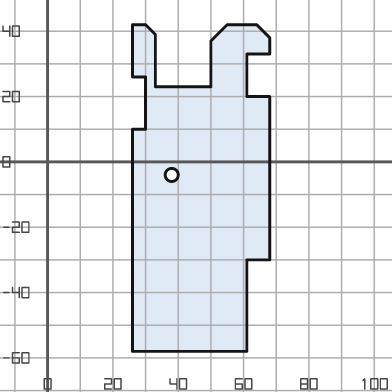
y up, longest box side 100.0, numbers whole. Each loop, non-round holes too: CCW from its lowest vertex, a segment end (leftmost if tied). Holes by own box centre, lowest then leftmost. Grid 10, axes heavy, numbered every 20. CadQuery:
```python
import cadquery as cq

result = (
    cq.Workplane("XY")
    .moveTo(26.0, -58.0)
    .lineTo(61.0, -58.0)
    .lineTo(61.0, -30.0)
    .lineTo(68.0, -30.0)
    .lineTo(68.0, 20.0)
    .lineTo(61.0, 20.0)
    .lineTo(61.0, 33.0)
    .lineTo(68.0, 33.0)
    .lineTo(68.0, 38.0)
    .lineTo(64.0, 42.0)
    .lineTo(55.0, 42.0)
    .lineTo(50.0, 37.0)
    .lineTo(50.0, 23.0)
    .lineTo(33.0, 23.0)
    .lineTo(33.0, 39.0)
    .lineTo(30.0, 42.0)
    .lineTo(26.0, 42.0)
    .lineTo(26.0, 26.0)
    .lineTo(30.0, 26.0)
    .lineTo(30.0, 10.0)
    .lineTo(26.0, 10.0)
    .close()
    .moveTo(38.0, -4.0)
    .circle(2.0)
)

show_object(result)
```